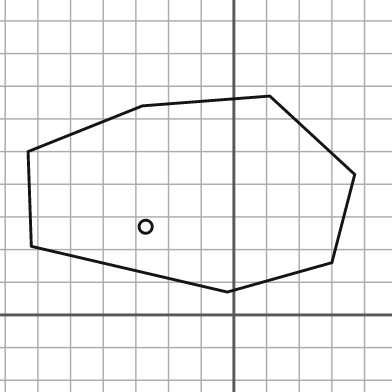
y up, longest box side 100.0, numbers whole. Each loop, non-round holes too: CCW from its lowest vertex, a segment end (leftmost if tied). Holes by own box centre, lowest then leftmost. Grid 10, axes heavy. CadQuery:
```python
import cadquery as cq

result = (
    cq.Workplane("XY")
    .moveTo(-2.0, 7.0)
    .lineTo(30.0, 16.0)
    .lineTo(37.0, 43.0)
    .lineTo(11.0, 67.0)
    .lineTo(-28.0, 64.0)
    .lineTo(-63.0, 50.0)
    .lineTo(-62.0, 21.0)
    .close()
    .moveTo(-27.0, 27.0)
    .circle(2.0)
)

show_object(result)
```